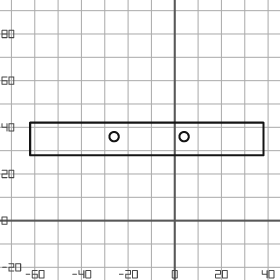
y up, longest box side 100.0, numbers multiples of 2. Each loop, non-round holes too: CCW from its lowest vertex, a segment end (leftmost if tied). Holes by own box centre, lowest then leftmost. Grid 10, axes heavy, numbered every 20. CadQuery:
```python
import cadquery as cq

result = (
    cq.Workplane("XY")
    .moveTo(-62.0, 28.0)
    .lineTo(38.0, 28.0)
    .lineTo(38.0, 42.0)
    .lineTo(-62.0, 42.0)
    .close()
    .moveTo(-26.0, 36.0)
    .circle(2.0)
    .moveTo(4.0, 36.0)
    .circle(2.0)
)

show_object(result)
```